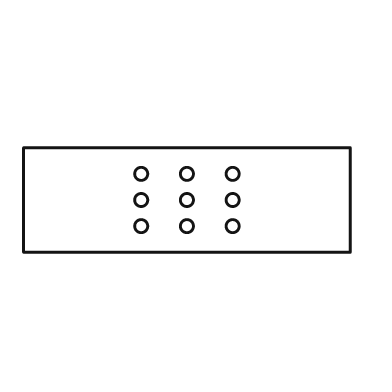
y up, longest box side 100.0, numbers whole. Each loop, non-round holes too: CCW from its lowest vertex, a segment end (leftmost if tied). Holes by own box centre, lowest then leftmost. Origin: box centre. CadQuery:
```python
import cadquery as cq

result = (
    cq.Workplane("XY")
    .moveTo(-50.0, -16.0)
    .lineTo(50.0, -16.0)
    .lineTo(50.0, 16.0)
    .lineTo(-50.0, 16.0)
    .close()
    .moveTo(-14.0, -8.0)
    .circle(2.0)
    .moveTo(0.0, -8.0)
    .circle(2.0)
    .moveTo(14.0, -8.0)
    .circle(2.0)
    .moveTo(-14.0, 0.0)
    .circle(2.0)
    .moveTo(0.0, 0.0)
    .circle(2.0)
    .moveTo(14.0, 0.0)
    .circle(2.0)
    .moveTo(-14.0, 8.0)
    .circle(2.0)
    .moveTo(0.0, 8.0)
    .circle(2.0)
    .moveTo(14.0, 8.0)
    .circle(2.0)
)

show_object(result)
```